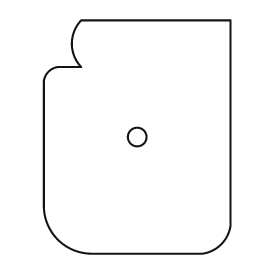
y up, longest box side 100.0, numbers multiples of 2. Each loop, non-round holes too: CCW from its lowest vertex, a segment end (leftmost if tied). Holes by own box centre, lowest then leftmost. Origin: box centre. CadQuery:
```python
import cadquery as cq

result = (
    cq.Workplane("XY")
    .moveTo(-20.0, -50.0)
    .lineTo(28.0, -50.0)
    .threePointArc((36.0, -46.0), (40.0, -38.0))
    .lineTo(40.0, 50.0)
    .lineTo(-24.0, 50.0)
    .threePointArc((-28.0, 40.0), (-24.0, 30.0))
    .lineTo(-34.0, 30.0)
    .threePointArc((-38.0, 28.0), (-40.0, 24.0))
    .lineTo(-40.0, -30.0)
    .threePointArc((-34.0, -44.0), (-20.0, -50.0))
    .close()
    .moveTo(0.0, 0.0)
    .circle(4.0)
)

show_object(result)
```